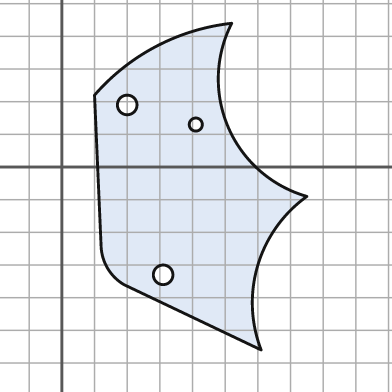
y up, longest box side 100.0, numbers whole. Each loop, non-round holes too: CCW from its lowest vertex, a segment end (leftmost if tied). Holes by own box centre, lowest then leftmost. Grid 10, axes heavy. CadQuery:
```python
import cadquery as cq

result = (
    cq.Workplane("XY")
    .moveTo(61.0, -56.0)
    .threePointArc((60.0, -30.0), (75.0, -9.0))
    .threePointArc((51.0, 12.0), (52.0, 44.0))
    .threePointArc((29.0, 37.0), (10.0, 22.0))
    .lineTo(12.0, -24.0)
    .threePointArc((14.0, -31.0), (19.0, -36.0))
    .close()
    .moveTo(31.0, -33.0)
    .circle(3.0)
    .moveTo(41.0, 13.0)
    .circle(2.0)
    .moveTo(20.0, 19.0)
    .circle(3.0)
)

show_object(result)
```